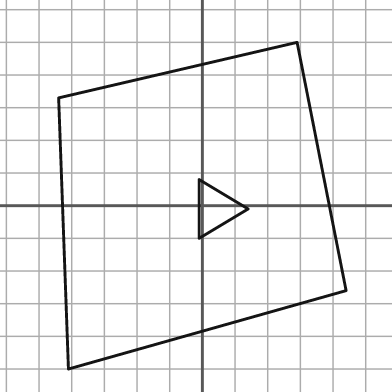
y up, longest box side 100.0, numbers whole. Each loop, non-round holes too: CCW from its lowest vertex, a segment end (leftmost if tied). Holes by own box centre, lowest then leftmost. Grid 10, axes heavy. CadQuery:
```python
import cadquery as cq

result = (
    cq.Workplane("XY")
    .moveTo(-41.0, -50.0)
    .lineTo(44.0, -26.0)
    .lineTo(29.0, 50.0)
    .lineTo(-44.0, 33.0)
    .close()
    .moveTo(-1.0, -10.0)
    .lineTo(14.0, -1.0)
    .lineTo(-1.0, 8.0)
    .close()
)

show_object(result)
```